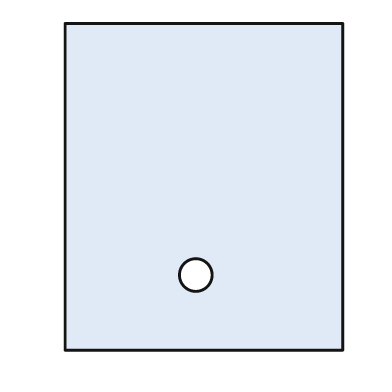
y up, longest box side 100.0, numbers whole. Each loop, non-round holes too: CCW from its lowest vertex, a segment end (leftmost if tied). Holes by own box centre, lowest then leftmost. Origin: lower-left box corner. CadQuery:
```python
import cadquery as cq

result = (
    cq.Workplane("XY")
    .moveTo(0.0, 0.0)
    .lineTo(85.0, 0.0)
    .lineTo(85.0, 100.0)
    .lineTo(0.0, 100.0)
    .close()
    .moveTo(40.0, 23.0)
    .circle(5.0)
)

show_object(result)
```